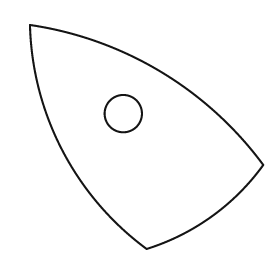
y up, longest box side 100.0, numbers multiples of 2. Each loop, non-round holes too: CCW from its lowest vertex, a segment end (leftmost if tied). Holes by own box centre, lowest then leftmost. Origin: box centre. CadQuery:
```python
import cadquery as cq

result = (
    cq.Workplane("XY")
    .moveTo(0.0, -48.0)
    .threePointArc((28.0, -34.0), (50.0, -12.0))
    .threePointArc((6.0, 28.0), (-50.0, 48.0))
    .threePointArc((-36.0, -6.0), (0.0, -48.0))
    .close()
    .moveTo(-10.0, 10.0)
    .circle(8.0)
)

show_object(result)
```